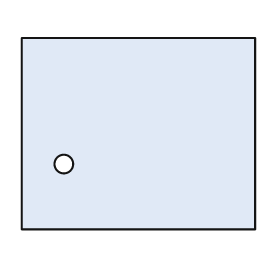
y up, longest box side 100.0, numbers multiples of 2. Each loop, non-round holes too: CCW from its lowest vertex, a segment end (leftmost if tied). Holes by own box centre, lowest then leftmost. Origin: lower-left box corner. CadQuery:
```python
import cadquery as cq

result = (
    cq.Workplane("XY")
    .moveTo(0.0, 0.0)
    .lineTo(100.0, 0.0)
    .lineTo(100.0, 82.0)
    .lineTo(0.0, 82.0)
    .close()
    .moveTo(18.0, 28.0)
    .circle(4.0)
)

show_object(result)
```